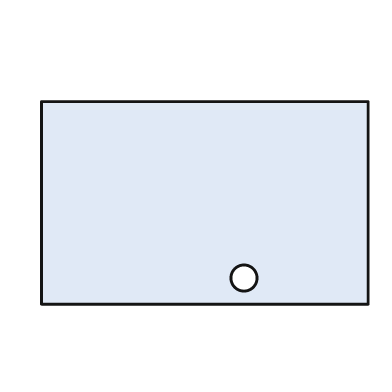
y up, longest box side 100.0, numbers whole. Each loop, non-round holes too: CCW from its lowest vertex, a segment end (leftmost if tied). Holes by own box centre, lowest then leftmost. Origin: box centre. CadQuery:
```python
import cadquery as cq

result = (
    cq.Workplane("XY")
    .moveTo(-50.0, -31.0)
    .lineTo(50.0, -31.0)
    .lineTo(50.0, 31.0)
    .lineTo(-50.0, 31.0)
    .close()
    .moveTo(12.0, -23.0)
    .circle(4.0)
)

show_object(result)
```